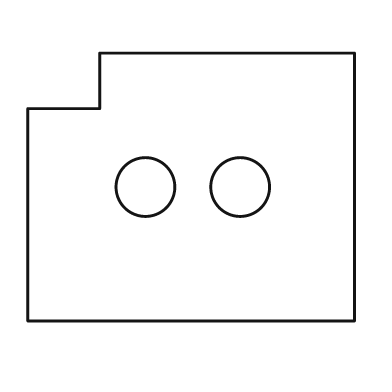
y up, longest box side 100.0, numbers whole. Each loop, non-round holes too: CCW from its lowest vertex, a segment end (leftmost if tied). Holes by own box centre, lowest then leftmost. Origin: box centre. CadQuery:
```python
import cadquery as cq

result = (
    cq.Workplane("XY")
    .moveTo(-50.0, -41.0)
    .lineTo(50.0, -41.0)
    .lineTo(50.0, 41.0)
    .lineTo(-28.0, 41.0)
    .lineTo(-28.0, 24.0)
    .lineTo(-50.0, 24.0)
    .close()
    .moveTo(-14.0, 0.0)
    .circle(9.0)
    .moveTo(15.0, 0.0)
    .circle(9.0)
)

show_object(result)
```